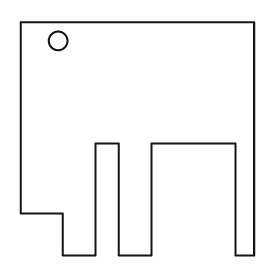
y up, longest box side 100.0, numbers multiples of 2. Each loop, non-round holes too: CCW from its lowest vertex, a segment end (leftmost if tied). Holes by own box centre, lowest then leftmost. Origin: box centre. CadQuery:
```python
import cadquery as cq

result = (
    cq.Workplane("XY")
    .moveTo(-32.0, -50.0)
    .lineTo(-18.0, -50.0)
    .lineTo(-18.0, -2.0)
    .lineTo(-8.0, -2.0)
    .lineTo(-8.0, -50.0)
    .lineTo(6.0, -50.0)
    .lineTo(6.0, -2.0)
    .lineTo(42.0, -2.0)
    .lineTo(42.0, -50.0)
    .lineTo(50.0, -50.0)
    .lineTo(50.0, 50.0)
    .lineTo(-50.0, 50.0)
    .lineTo(-50.0, -32.0)
    .lineTo(-32.0, -32.0)
    .close()
    .moveTo(-34.0, 42.0)
    .circle(4.0)
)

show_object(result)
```